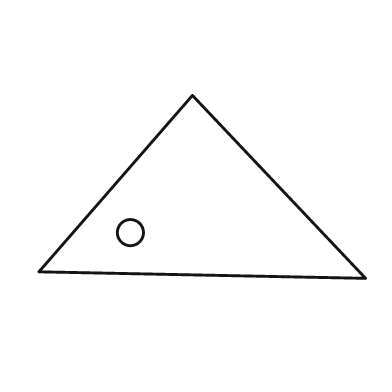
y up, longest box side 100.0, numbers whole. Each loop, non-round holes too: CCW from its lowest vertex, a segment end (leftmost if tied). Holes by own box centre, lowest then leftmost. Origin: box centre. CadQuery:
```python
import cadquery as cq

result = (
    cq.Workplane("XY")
    .moveTo(50.0, -28.0)
    .lineTo(-3.0, 28.0)
    .lineTo(-50.0, -26.0)
    .close()
    .moveTo(-22.0, -14.0)
    .circle(4.0)
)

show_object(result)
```